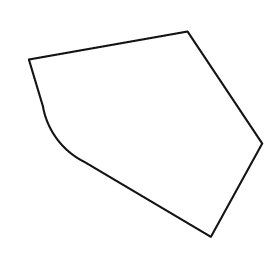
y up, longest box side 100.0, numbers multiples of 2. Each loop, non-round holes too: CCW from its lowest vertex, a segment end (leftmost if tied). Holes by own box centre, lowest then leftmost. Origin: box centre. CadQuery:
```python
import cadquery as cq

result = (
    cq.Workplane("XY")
    .moveTo(28.0, -44.0)
    .lineTo(50.0, -4.0)
    .lineTo(18.0, 44.0)
    .lineTo(-50.0, 32.0)
    .lineTo(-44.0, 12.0)
    .threePointArc((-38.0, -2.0), (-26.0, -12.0))
    .close()
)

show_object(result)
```